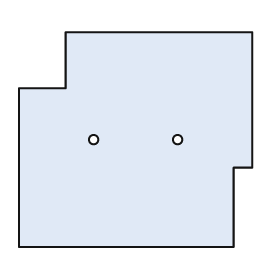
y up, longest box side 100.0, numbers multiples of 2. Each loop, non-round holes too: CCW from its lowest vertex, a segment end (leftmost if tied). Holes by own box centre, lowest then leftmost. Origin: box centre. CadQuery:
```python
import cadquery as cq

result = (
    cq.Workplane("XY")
    .moveTo(-50.0, -46.0)
    .lineTo(42.0, -46.0)
    .lineTo(42.0, -12.0)
    .lineTo(50.0, -12.0)
    .lineTo(50.0, 46.0)
    .lineTo(-30.0, 46.0)
    .lineTo(-30.0, 22.0)
    .lineTo(-50.0, 22.0)
    .close()
    .moveTo(-18.0, 0.0)
    .circle(2.0)
    .moveTo(18.0, 0.0)
    .circle(2.0)
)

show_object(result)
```